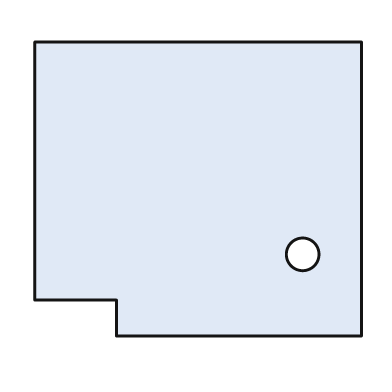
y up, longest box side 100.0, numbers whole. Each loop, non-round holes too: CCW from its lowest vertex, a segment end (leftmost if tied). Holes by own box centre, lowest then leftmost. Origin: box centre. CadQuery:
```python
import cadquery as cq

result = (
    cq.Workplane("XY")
    .moveTo(-25.0, -45.0)
    .lineTo(50.0, -45.0)
    .lineTo(50.0, 45.0)
    .lineTo(-50.0, 45.0)
    .lineTo(-50.0, -34.0)
    .lineTo(-25.0, -34.0)
    .close()
    .moveTo(32.0, -20.0)
    .circle(5.0)
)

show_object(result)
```